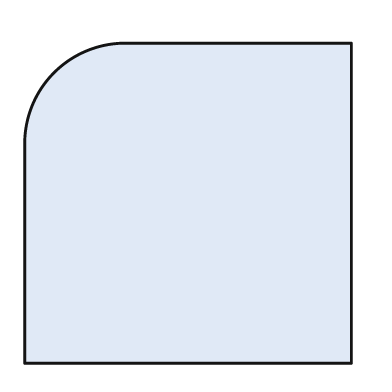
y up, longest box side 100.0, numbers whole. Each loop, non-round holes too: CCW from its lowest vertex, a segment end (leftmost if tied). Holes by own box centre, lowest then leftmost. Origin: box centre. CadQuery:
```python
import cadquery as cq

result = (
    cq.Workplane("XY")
    .moveTo(-50.0, -49.0)
    .lineTo(50.0, -49.0)
    .lineTo(50.0, 49.0)
    .lineTo(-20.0, 49.0)
    .threePointArc((-41.0, 40.0), (-50.0, 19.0))
    .close()
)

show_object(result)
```